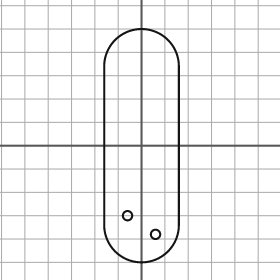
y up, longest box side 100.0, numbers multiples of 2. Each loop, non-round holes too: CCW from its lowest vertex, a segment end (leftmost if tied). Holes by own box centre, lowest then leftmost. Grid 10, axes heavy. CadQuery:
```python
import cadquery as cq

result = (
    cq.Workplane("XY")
    .moveTo(-16.0, -34.0)
    .threePointArc((0.0, -50.0), (16.0, -34.0))
    .lineTo(16.0, 34.0)
    .threePointArc((0.0, 50.0), (-16.0, 34.0))
    .close()
    .moveTo(6.0, -38.0)
    .circle(2.0)
    .moveTo(-6.0, -30.0)
    .circle(2.0)
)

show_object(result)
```